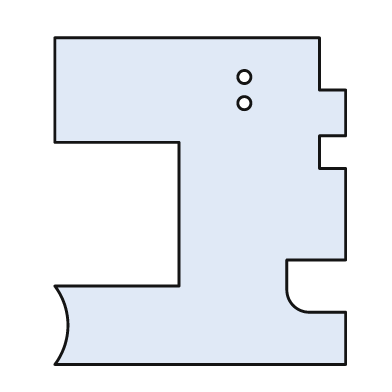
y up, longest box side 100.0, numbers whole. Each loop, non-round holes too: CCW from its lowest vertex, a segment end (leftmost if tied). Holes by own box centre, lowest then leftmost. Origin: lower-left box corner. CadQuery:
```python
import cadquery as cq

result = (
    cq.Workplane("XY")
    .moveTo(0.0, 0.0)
    .lineTo(89.0, 0.0)
    .lineTo(89.0, 16.0)
    .lineTo(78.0, 16.0)
    .threePointArc((73.0, 18.0), (71.0, 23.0))
    .lineTo(71.0, 32.0)
    .lineTo(89.0, 32.0)
    .lineTo(89.0, 60.0)
    .lineTo(81.0, 60.0)
    .lineTo(81.0, 70.0)
    .lineTo(89.0, 70.0)
    .lineTo(89.0, 84.0)
    .lineTo(81.0, 84.0)
    .lineTo(81.0, 100.0)
    .lineTo(0.0, 100.0)
    .lineTo(0.0, 68.0)
    .lineTo(38.0, 68.0)
    .lineTo(38.0, 24.0)
    .lineTo(0.0, 24.0)
    .threePointArc((4.0, 12.0), (0.0, 0.0))
    .close()
    .moveTo(58.0, 80.0)
    .circle(2.0)
    .moveTo(58.0, 88.0)
    .circle(2.0)
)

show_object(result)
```